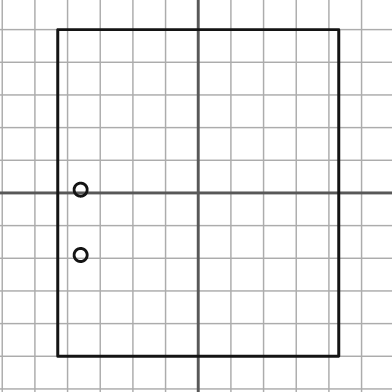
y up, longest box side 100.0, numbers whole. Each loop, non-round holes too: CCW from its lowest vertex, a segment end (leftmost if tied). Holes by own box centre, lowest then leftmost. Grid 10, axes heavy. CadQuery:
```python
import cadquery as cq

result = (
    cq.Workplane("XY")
    .moveTo(-43.0, -50.0)
    .lineTo(43.0, -50.0)
    .lineTo(43.0, 50.0)
    .lineTo(-43.0, 50.0)
    .close()
    .moveTo(-36.0, -19.0)
    .circle(2.0)
    .moveTo(-36.0, 1.0)
    .circle(2.0)
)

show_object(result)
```